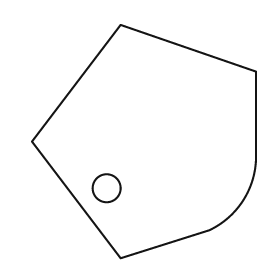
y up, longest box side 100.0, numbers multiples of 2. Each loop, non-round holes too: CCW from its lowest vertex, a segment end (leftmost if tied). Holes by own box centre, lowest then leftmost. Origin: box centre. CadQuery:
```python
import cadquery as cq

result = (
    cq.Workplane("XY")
    .moveTo(-10.0, -50.0)
    .lineTo(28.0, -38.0)
    .threePointArc((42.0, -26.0), (48.0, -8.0))
    .lineTo(48.0, 30.0)
    .lineTo(-10.0, 50.0)
    .lineTo(-48.0, 0.0)
    .close()
    .moveTo(-16.0, -20.0)
    .circle(6.0)
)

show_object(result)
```